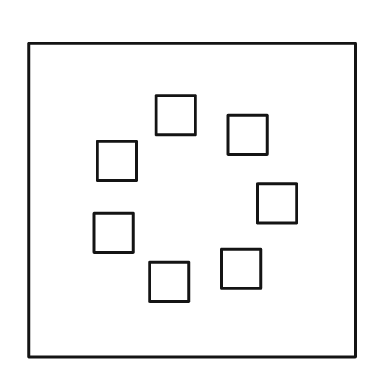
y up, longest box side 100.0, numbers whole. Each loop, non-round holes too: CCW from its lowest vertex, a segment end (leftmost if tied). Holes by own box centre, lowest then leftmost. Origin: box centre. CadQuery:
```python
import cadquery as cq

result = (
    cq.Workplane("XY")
    .moveTo(-50.0, -48.0)
    .lineTo(50.0, -48.0)
    .lineTo(50.0, 48.0)
    .lineTo(-50.0, 48.0)
    .close()
    .moveTo(-13.0, -31.0)
    .lineTo(-1.0, -31.0)
    .lineTo(-1.0, -19.0)
    .lineTo(-13.0, -19.0)
    .close()
    .moveTo(9.0, -27.0)
    .lineTo(21.0, -27.0)
    .lineTo(21.0, -15.0)
    .lineTo(9.0, -15.0)
    .close()
    .moveTo(-30.0, -16.0)
    .lineTo(-18.0, -16.0)
    .lineTo(-18.0, -4.0)
    .lineTo(-30.0, -4.0)
    .close()
    .moveTo(20.0, -7.0)
    .lineTo(32.0, -7.0)
    .lineTo(32.0, 5.0)
    .lineTo(20.0, 5.0)
    .close()
    .moveTo(-29.0, 6.0)
    .lineTo(-17.0, 6.0)
    .lineTo(-17.0, 18.0)
    .lineTo(-29.0, 18.0)
    .close()
    .moveTo(11.0, 14.0)
    .lineTo(23.0, 14.0)
    .lineTo(23.0, 26.0)
    .lineTo(11.0, 26.0)
    .close()
    .moveTo(-11.0, 20.0)
    .lineTo(1.0, 20.0)
    .lineTo(1.0, 32.0)
    .lineTo(-11.0, 32.0)
    .close()
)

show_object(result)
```